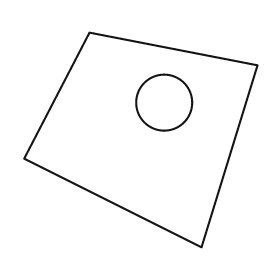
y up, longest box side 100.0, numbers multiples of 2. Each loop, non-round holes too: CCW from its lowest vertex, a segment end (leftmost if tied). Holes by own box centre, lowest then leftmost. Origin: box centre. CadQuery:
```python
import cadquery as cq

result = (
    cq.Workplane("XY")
    .moveTo(26.0, -46.0)
    .lineTo(50.0, 32.0)
    .lineTo(-22.0, 46.0)
    .lineTo(-50.0, -8.0)
    .close()
    .moveTo(10.0, 16.0)
    .circle(12.0)
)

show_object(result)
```